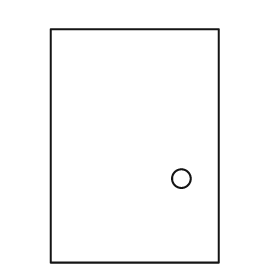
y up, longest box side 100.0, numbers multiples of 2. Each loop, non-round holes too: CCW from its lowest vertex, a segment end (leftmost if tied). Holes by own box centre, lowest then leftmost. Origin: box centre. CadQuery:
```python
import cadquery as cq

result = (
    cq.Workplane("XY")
    .moveTo(-36.0, -50.0)
    .lineTo(36.0, -50.0)
    .lineTo(36.0, 50.0)
    .lineTo(-36.0, 50.0)
    .close()
    .moveTo(20.0, -14.0)
    .circle(4.0)
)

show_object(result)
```